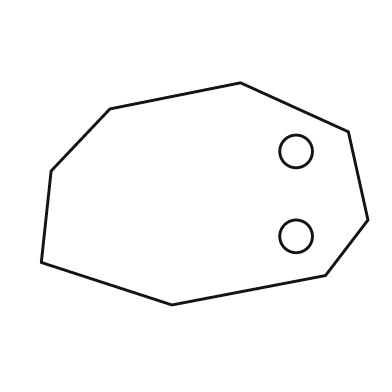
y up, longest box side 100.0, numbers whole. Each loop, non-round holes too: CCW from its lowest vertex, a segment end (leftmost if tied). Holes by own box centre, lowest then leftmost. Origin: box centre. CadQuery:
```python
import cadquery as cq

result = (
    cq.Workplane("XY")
    .moveTo(-10.0, -34.0)
    .lineTo(37.0, -25.0)
    .lineTo(50.0, -8.0)
    .lineTo(44.0, 19.0)
    .lineTo(11.0, 34.0)
    .lineTo(-29.0, 26.0)
    .lineTo(-47.0, 7.0)
    .lineTo(-50.0, -21.0)
    .close()
    .moveTo(28.0, -13.0)
    .circle(5.0)
    .moveTo(28.0, 13.0)
    .circle(5.0)
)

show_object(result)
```